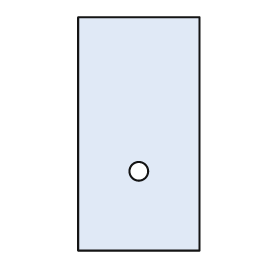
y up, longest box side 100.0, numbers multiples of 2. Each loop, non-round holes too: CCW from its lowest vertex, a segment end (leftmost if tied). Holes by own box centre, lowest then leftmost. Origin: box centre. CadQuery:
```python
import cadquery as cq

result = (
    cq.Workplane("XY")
    .moveTo(-26.0, -50.0)
    .lineTo(26.0, -50.0)
    .lineTo(26.0, 50.0)
    .lineTo(-26.0, 50.0)
    .close()
    .moveTo(0.0, -16.0)
    .circle(4.0)
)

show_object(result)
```